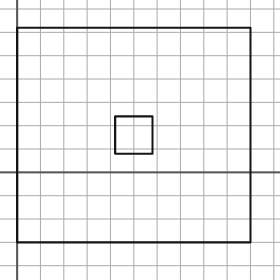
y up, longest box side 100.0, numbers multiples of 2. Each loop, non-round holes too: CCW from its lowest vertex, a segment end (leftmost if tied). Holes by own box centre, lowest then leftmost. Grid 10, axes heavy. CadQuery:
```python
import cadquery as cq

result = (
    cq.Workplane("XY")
    .moveTo(0.0, -30.0)
    .lineTo(100.0, -30.0)
    .lineTo(100.0, 62.0)
    .lineTo(0.0, 62.0)
    .close()
    .moveTo(42.0, 8.0)
    .lineTo(58.0, 8.0)
    .lineTo(58.0, 24.0)
    .lineTo(42.0, 24.0)
    .close()
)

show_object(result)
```